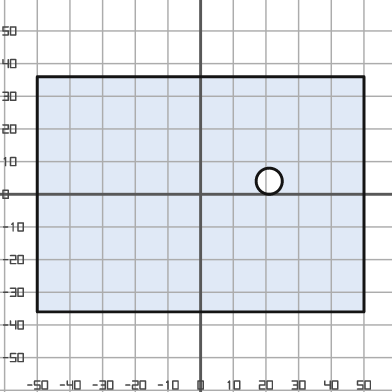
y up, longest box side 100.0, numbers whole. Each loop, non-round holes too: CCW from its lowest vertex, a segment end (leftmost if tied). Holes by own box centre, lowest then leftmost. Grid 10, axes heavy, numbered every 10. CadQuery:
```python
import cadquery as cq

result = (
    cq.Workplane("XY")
    .moveTo(-50.0, -36.0)
    .lineTo(50.0, -36.0)
    .lineTo(50.0, 36.0)
    .lineTo(-50.0, 36.0)
    .close()
    .moveTo(21.0, 4.0)
    .circle(4.0)
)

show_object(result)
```